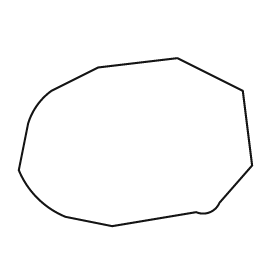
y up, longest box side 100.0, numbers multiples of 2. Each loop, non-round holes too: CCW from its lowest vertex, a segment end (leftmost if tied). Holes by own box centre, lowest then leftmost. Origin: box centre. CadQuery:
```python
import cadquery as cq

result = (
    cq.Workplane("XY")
    .moveTo(-10.0, -36.0)
    .lineTo(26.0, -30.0)
    .threePointArc((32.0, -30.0), (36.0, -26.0))
    .lineTo(50.0, -10.0)
    .lineTo(46.0, 22.0)
    .lineTo(18.0, 36.0)
    .lineTo(-16.0, 32.0)
    .lineTo(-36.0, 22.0)
    .threePointArc((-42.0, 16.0), (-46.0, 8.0))
    .lineTo(-50.0, -12.0)
    .threePointArc((-42.0, -24.0), (-30.0, -32.0))
    .close()
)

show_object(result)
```